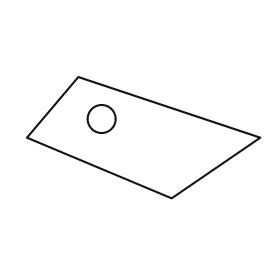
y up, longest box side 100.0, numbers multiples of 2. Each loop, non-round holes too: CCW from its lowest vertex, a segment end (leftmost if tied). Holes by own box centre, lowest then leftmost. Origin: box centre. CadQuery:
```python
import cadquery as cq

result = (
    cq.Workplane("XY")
    .moveTo(12.0, -26.0)
    .lineTo(50.0, 0.0)
    .lineTo(-28.0, 26.0)
    .lineTo(-50.0, 0.0)
    .close()
    .moveTo(-18.0, 8.0)
    .circle(6.0)
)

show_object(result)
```